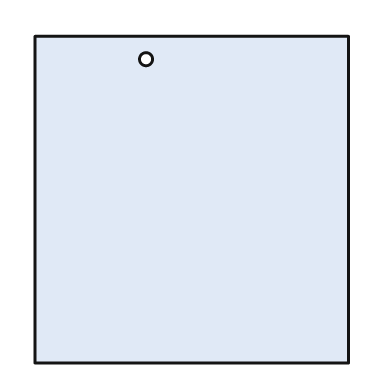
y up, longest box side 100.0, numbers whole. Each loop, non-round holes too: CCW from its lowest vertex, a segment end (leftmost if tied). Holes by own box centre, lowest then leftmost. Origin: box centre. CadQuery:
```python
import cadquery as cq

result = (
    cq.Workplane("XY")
    .moveTo(-48.0, -50.0)
    .lineTo(48.0, -50.0)
    .lineTo(48.0, 50.0)
    .lineTo(-48.0, 50.0)
    .close()
    .moveTo(-14.0, 43.0)
    .circle(2.0)
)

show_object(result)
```